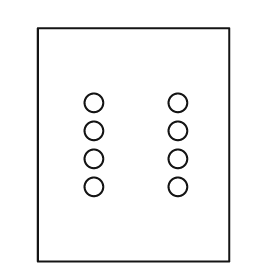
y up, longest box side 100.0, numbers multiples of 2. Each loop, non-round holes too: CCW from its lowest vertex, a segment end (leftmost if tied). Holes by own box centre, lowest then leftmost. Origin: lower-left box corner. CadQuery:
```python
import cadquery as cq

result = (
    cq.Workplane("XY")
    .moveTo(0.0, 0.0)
    .lineTo(82.0, 0.0)
    .lineTo(82.0, 100.0)
    .lineTo(0.0, 100.0)
    .close()
    .moveTo(24.0, 32.0)
    .circle(4.0)
    .moveTo(60.0, 32.0)
    .circle(4.0)
    .moveTo(24.0, 44.0)
    .circle(4.0)
    .moveTo(60.0, 44.0)
    .circle(4.0)
    .moveTo(24.0, 56.0)
    .circle(4.0)
    .moveTo(60.0, 56.0)
    .circle(4.0)
    .moveTo(24.0, 68.0)
    .circle(4.0)
    .moveTo(60.0, 68.0)
    .circle(4.0)
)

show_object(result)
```